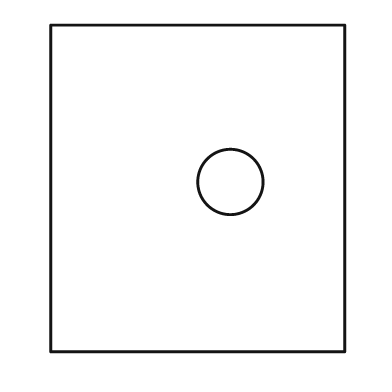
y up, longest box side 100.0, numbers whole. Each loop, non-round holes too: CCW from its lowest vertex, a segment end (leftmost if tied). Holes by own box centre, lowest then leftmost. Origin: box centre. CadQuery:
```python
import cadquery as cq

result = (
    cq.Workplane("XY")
    .moveTo(-45.0, -50.0)
    .lineTo(45.0, -50.0)
    .lineTo(45.0, 50.0)
    .lineTo(-45.0, 50.0)
    .close()
    .moveTo(10.0, 2.0)
    .circle(10.0)
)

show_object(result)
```